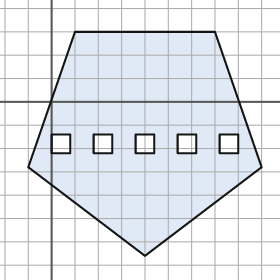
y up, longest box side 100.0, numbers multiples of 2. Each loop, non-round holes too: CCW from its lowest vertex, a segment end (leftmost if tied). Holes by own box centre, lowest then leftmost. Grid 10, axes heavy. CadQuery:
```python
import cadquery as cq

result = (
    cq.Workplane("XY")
    .moveTo(40.0, -66.0)
    .lineTo(90.0, -28.0)
    .lineTo(70.0, 30.0)
    .lineTo(10.0, 30.0)
    .lineTo(-10.0, -28.0)
    .close()
    .moveTo(0.0, -22.0)
    .lineTo(8.0, -22.0)
    .lineTo(8.0, -14.0)
    .lineTo(0.0, -14.0)
    .close()
    .moveTo(18.0, -22.0)
    .lineTo(26.0, -22.0)
    .lineTo(26.0, -14.0)
    .lineTo(18.0, -14.0)
    .close()
    .moveTo(36.0, -22.0)
    .lineTo(44.0, -22.0)
    .lineTo(44.0, -14.0)
    .lineTo(36.0, -14.0)
    .close()
    .moveTo(54.0, -22.0)
    .lineTo(62.0, -22.0)
    .lineTo(62.0, -14.0)
    .lineTo(54.0, -14.0)
    .close()
    .moveTo(72.0, -22.0)
    .lineTo(80.0, -22.0)
    .lineTo(80.0, -14.0)
    .lineTo(72.0, -14.0)
    .close()
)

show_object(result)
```